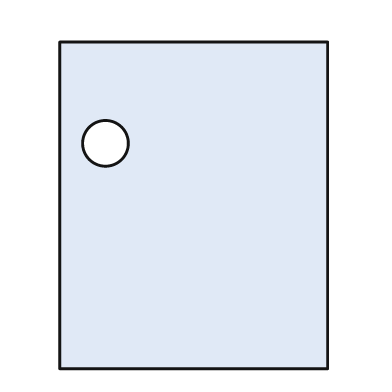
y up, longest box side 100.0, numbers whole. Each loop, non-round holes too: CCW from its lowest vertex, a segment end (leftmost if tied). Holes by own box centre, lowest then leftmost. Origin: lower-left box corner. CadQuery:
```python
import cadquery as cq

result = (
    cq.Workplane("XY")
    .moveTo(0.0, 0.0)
    .lineTo(82.0, 0.0)
    .lineTo(82.0, 100.0)
    .lineTo(0.0, 100.0)
    .close()
    .moveTo(14.0, 69.0)
    .circle(7.0)
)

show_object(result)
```